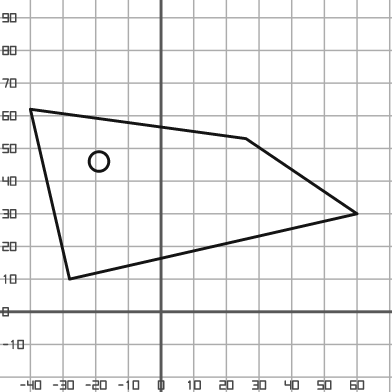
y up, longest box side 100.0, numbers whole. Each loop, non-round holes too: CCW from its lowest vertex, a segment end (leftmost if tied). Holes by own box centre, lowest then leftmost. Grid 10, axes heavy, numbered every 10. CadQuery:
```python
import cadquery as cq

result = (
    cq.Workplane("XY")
    .moveTo(-28.0, 10.0)
    .lineTo(60.0, 30.0)
    .lineTo(26.0, 53.0)
    .lineTo(-40.0, 62.0)
    .close()
    .moveTo(-19.0, 46.0)
    .circle(3.0)
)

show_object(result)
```